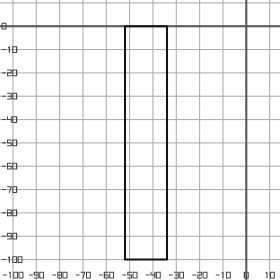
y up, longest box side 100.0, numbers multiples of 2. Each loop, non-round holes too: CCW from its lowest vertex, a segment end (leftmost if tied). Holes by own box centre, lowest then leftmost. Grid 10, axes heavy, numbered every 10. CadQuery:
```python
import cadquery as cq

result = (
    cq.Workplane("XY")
    .moveTo(-52.0, -100.0)
    .lineTo(-34.0, -100.0)
    .lineTo(-34.0, 0.0)
    .lineTo(-52.0, 0.0)
    .close()
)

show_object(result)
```